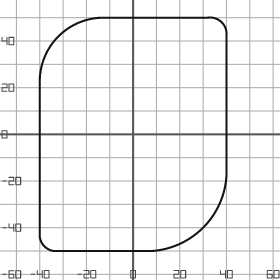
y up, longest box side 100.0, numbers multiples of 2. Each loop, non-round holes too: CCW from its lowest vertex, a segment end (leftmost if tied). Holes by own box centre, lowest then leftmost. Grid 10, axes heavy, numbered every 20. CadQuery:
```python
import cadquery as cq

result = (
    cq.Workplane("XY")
    .moveTo(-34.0, -50.0)
    .lineTo(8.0, -50.0)
    .threePointArc((30.0, -40.0), (40.0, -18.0))
    .lineTo(40.0, 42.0)
    .threePointArc((38.0, 48.0), (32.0, 50.0))
    .lineTo(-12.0, 50.0)
    .threePointArc((-32.0, 42.0), (-40.0, 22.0))
    .lineTo(-40.0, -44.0)
    .threePointArc((-38.0, -48.0), (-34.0, -50.0))
    .close()
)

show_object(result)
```